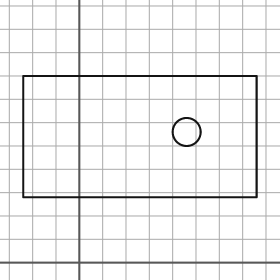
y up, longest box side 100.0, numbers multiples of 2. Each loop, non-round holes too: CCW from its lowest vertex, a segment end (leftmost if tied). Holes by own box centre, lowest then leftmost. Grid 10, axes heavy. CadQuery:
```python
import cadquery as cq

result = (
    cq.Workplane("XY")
    .moveTo(-24.0, 28.0)
    .lineTo(76.0, 28.0)
    .lineTo(76.0, 80.0)
    .lineTo(-24.0, 80.0)
    .close()
    .moveTo(46.0, 56.0)
    .circle(6.0)
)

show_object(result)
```